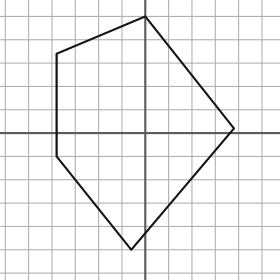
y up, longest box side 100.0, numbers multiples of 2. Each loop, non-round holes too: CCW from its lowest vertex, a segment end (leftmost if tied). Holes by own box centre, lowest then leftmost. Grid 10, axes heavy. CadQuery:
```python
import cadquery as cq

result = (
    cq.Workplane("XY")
    .moveTo(-6.0, -50.0)
    .lineTo(38.0, 2.0)
    .lineTo(0.0, 50.0)
    .lineTo(-38.0, 34.0)
    .lineTo(-38.0, -10.0)
    .close()
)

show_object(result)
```